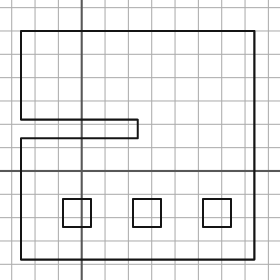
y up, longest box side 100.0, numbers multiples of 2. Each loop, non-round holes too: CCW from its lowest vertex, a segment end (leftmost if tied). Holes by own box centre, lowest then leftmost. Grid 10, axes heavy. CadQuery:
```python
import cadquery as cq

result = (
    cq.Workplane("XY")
    .moveTo(-26.0, -38.0)
    .lineTo(74.0, -38.0)
    .lineTo(74.0, 60.0)
    .lineTo(-26.0, 60.0)
    .lineTo(-26.0, 22.0)
    .lineTo(24.0, 22.0)
    .lineTo(24.0, 14.0)
    .lineTo(-26.0, 14.0)
    .close()
    .moveTo(-8.0, -24.0)
    .lineTo(4.0, -24.0)
    .lineTo(4.0, -12.0)
    .lineTo(-8.0, -12.0)
    .close()
    .moveTo(22.0, -24.0)
    .lineTo(34.0, -24.0)
    .lineTo(34.0, -12.0)
    .lineTo(22.0, -12.0)
    .close()
    .moveTo(52.0, -24.0)
    .lineTo(64.0, -24.0)
    .lineTo(64.0, -12.0)
    .lineTo(52.0, -12.0)
    .close()
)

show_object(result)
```